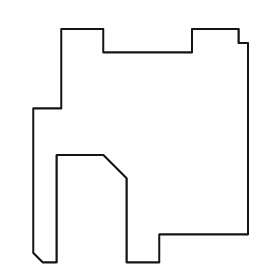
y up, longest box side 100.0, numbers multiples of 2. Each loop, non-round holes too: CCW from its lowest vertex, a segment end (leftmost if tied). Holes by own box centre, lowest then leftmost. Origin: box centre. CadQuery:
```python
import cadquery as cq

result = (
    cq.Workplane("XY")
    .moveTo(-42.0, -50.0)
    .lineTo(-36.0, -50.0)
    .lineTo(-36.0, -4.0)
    .lineTo(-16.0, -4.0)
    .lineTo(-6.0, -14.0)
    .lineTo(-6.0, -50.0)
    .lineTo(8.0, -50.0)
    .lineTo(8.0, -38.0)
    .lineTo(46.0, -38.0)
    .lineTo(46.0, 44.0)
    .lineTo(42.0, 44.0)
    .lineTo(42.0, 50.0)
    .lineTo(22.0, 50.0)
    .lineTo(22.0, 40.0)
    .lineTo(-16.0, 40.0)
    .lineTo(-16.0, 50.0)
    .lineTo(-34.0, 50.0)
    .lineTo(-34.0, 16.0)
    .lineTo(-46.0, 16.0)
    .lineTo(-46.0, -46.0)
    .close()
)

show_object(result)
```